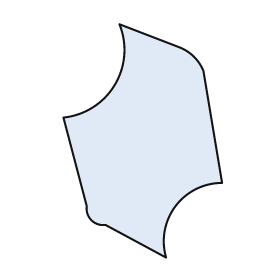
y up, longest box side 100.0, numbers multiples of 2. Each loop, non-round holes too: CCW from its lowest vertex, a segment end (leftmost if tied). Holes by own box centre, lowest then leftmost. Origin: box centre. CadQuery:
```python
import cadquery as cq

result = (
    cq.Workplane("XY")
    .moveTo(10.0, -50.0)
    .threePointArc((14.0, -28.0), (34.0, -18.0))
    .lineTo(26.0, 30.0)
    .threePointArc((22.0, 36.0), (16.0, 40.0))
    .lineTo(-10.0, 50.0)
    .threePointArc((-12.0, 24.0), (-34.0, 10.0))
    .lineTo(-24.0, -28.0)
    .threePointArc((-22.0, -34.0), (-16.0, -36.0))
    .close()
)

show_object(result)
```